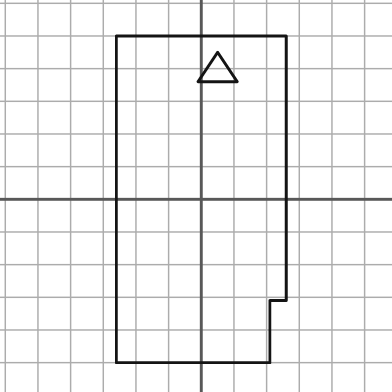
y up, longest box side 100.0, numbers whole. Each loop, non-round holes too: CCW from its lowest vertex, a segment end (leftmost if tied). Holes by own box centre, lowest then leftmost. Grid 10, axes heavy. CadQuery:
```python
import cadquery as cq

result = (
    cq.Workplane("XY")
    .moveTo(-26.0, -50.0)
    .lineTo(21.0, -50.0)
    .lineTo(21.0, -31.0)
    .lineTo(26.0, -31.0)
    .lineTo(26.0, 50.0)
    .lineTo(-26.0, 50.0)
    .close()
    .moveTo(-1.0, 36.0)
    .lineTo(11.0, 36.0)
    .lineTo(5.0, 45.0)
    .close()
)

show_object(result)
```